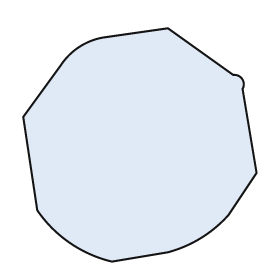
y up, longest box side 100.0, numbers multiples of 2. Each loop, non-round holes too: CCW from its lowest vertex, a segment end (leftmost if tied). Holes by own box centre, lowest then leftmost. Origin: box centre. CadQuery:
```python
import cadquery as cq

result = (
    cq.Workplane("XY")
    .moveTo(-12.0, -50.0)
    .lineTo(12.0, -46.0)
    .threePointArc((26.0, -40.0), (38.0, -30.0))
    .lineTo(50.0, -12.0)
    .lineTo(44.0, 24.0)
    .threePointArc((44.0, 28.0), (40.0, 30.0))
    .lineTo(12.0, 50.0)
    .lineTo(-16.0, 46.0)
    .threePointArc((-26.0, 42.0), (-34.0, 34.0))
    .lineTo(-50.0, 12.0)
    .lineTo(-44.0, -28.0)
    .threePointArc((-30.0, -42.0), (-12.0, -50.0))
    .close()
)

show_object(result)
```